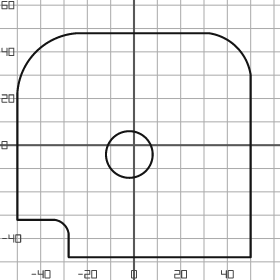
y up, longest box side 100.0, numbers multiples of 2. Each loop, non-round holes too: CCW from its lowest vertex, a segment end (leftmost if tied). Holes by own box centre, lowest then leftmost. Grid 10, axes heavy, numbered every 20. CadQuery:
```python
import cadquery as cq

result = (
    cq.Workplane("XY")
    .moveTo(-28.0, -48.0)
    .lineTo(50.0, -48.0)
    .lineTo(50.0, 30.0)
    .threePointArc((44.0, 42.0), (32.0, 48.0))
    .lineTo(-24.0, 48.0)
    .threePointArc((-42.0, 40.0), (-50.0, 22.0))
    .lineTo(-50.0, -32.0)
    .lineTo(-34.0, -32.0)
    .threePointArc((-30.0, -34.0), (-28.0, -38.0))
    .close()
    .moveTo(-2.0, -4.0)
    .circle(10.0)
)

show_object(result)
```